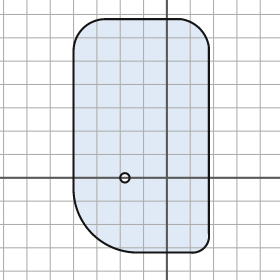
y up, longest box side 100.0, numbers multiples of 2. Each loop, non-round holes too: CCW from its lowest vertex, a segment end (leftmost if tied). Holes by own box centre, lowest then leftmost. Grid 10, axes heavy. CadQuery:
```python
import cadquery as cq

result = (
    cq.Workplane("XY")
    .moveTo(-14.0, -32.0)
    .lineTo(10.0, -32.0)
    .threePointArc((16.0, -30.0), (18.0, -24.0))
    .lineTo(18.0, 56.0)
    .threePointArc((14.0, 64.0), (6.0, 68.0))
    .lineTo(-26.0, 68.0)
    .threePointArc((-36.0, 64.0), (-40.0, 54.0))
    .lineTo(-40.0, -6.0)
    .threePointArc((-32.0, -24.0), (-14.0, -32.0))
    .close()
    .moveTo(-18.0, 0.0)
    .circle(2.0)
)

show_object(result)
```